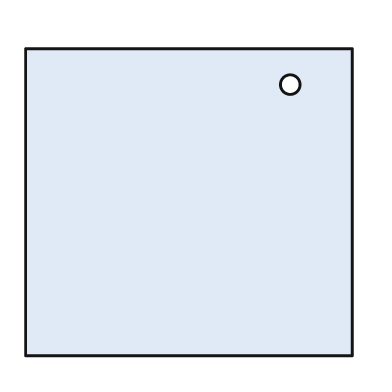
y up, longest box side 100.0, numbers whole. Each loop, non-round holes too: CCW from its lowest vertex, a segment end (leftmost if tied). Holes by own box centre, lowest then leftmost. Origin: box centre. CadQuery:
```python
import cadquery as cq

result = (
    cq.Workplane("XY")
    .moveTo(-50.0, -47.0)
    .lineTo(50.0, -47.0)
    .lineTo(50.0, 47.0)
    .lineTo(-50.0, 47.0)
    .close()
    .moveTo(31.0, 36.0)
    .circle(3.0)
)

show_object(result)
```